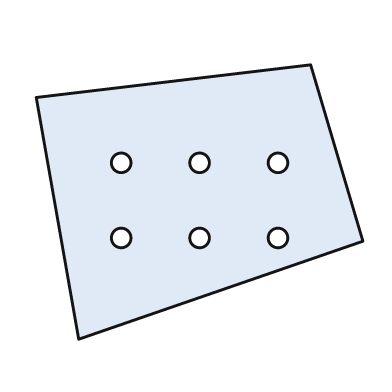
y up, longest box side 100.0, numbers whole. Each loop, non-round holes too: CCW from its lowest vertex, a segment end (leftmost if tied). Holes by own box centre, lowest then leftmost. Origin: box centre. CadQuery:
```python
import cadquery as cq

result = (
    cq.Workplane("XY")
    .moveTo(-37.0, -42.0)
    .lineTo(50.0, -12.0)
    .lineTo(34.0, 42.0)
    .lineTo(-50.0, 32.0)
    .close()
    .moveTo(-24.0, -11.0)
    .circle(3.0)
    .moveTo(0.0, -11.0)
    .circle(3.0)
    .moveTo(24.0, -11.0)
    .circle(3.0)
    .moveTo(-24.0, 12.0)
    .circle(3.0)
    .moveTo(0.0, 12.0)
    .circle(3.0)
    .moveTo(24.0, 12.0)
    .circle(3.0)
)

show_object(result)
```